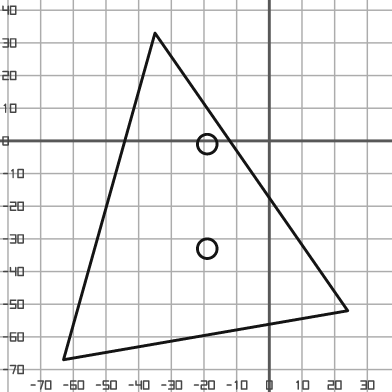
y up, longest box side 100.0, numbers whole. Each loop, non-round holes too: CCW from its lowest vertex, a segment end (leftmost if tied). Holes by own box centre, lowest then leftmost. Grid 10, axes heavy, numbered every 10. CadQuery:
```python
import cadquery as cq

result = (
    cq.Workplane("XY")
    .moveTo(-63.0, -67.0)
    .lineTo(24.0, -52.0)
    .lineTo(-35.0, 33.0)
    .close()
    .moveTo(-19.0, -33.0)
    .circle(3.0)
    .moveTo(-19.0, -1.0)
    .circle(3.0)
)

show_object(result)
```